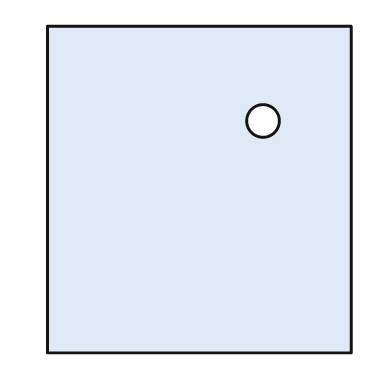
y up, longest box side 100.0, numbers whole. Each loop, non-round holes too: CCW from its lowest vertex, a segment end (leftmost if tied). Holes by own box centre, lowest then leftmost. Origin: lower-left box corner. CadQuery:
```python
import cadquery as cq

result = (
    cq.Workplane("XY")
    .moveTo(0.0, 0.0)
    .lineTo(93.0, 0.0)
    .lineTo(93.0, 100.0)
    .lineTo(0.0, 100.0)
    .close()
    .moveTo(66.0, 71.0)
    .circle(5.0)
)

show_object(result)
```